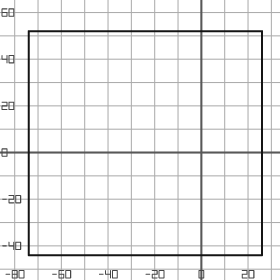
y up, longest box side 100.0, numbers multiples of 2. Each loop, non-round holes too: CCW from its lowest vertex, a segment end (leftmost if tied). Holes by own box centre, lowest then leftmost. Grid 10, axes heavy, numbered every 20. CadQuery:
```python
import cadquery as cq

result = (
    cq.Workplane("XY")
    .moveTo(-74.0, -44.0)
    .lineTo(26.0, -44.0)
    .lineTo(26.0, 52.0)
    .lineTo(-74.0, 52.0)
    .close()
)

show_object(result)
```